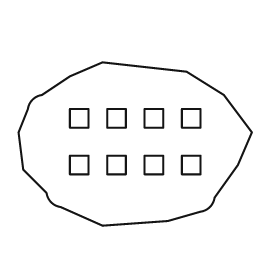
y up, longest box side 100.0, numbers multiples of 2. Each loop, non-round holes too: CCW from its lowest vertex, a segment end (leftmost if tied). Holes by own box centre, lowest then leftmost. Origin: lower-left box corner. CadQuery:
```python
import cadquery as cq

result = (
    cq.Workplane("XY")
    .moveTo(36.0, 0.0)
    .lineTo(64.0, 2.0)
    .lineTo(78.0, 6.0)
    .threePointArc((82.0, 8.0), (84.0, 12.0))
    .lineTo(94.0, 26.0)
    .lineTo(100.0, 40.0)
    .lineTo(88.0, 56.0)
    .lineTo(72.0, 66.0)
    .lineTo(36.0, 70.0)
    .lineTo(22.0, 64.0)
    .lineTo(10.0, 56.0)
    .threePointArc((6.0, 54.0), (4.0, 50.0))
    .lineTo(0.0, 40.0)
    .lineTo(2.0, 24.0)
    .lineTo(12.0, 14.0)
    .threePointArc((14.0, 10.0), (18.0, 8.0))
    .close()
    .moveTo(22.0, 22.0)
    .lineTo(30.0, 22.0)
    .lineTo(30.0, 30.0)
    .lineTo(22.0, 30.0)
    .close()
    .moveTo(38.0, 22.0)
    .lineTo(46.0, 22.0)
    .lineTo(46.0, 30.0)
    .lineTo(38.0, 30.0)
    .close()
    .moveTo(54.0, 22.0)
    .lineTo(62.0, 22.0)
    .lineTo(62.0, 30.0)
    .lineTo(54.0, 30.0)
    .close()
    .moveTo(70.0, 22.0)
    .lineTo(78.0, 22.0)
    .lineTo(78.0, 30.0)
    .lineTo(70.0, 30.0)
    .close()
    .moveTo(22.0, 42.0)
    .lineTo(30.0, 42.0)
    .lineTo(30.0, 50.0)
    .lineTo(22.0, 50.0)
    .close()
    .moveTo(38.0, 42.0)
    .lineTo(46.0, 42.0)
    .lineTo(46.0, 50.0)
    .lineTo(38.0, 50.0)
    .close()
    .moveTo(54.0, 42.0)
    .lineTo(62.0, 42.0)
    .lineTo(62.0, 50.0)
    .lineTo(54.0, 50.0)
    .close()
    .moveTo(70.0, 42.0)
    .lineTo(78.0, 42.0)
    .lineTo(78.0, 50.0)
    .lineTo(70.0, 50.0)
    .close()
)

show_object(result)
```